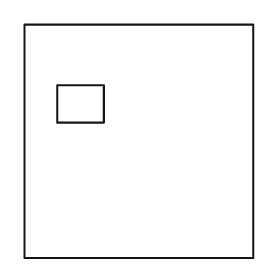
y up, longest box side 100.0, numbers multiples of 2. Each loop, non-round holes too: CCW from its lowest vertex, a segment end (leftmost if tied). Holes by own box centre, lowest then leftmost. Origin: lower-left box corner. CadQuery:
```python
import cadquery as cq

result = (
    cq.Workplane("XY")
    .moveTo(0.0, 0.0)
    .lineTo(98.0, 0.0)
    .lineTo(98.0, 100.0)
    .lineTo(0.0, 100.0)
    .close()
    .moveTo(14.0, 58.0)
    .lineTo(34.0, 58.0)
    .lineTo(34.0, 74.0)
    .lineTo(14.0, 74.0)
    .close()
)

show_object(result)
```